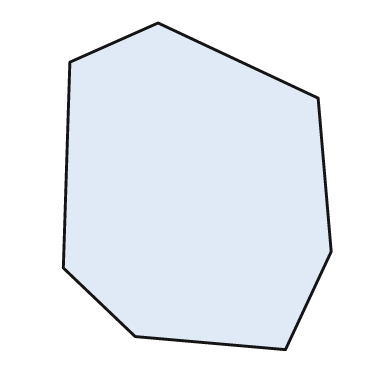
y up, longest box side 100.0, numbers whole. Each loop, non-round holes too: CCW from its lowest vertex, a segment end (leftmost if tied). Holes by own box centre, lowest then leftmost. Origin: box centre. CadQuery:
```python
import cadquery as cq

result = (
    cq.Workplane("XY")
    .moveTo(27.0, -50.0)
    .lineTo(41.0, -20.0)
    .lineTo(37.0, 27.0)
    .lineTo(-12.0, 50.0)
    .lineTo(-39.0, 38.0)
    .lineTo(-41.0, -25.0)
    .lineTo(-19.0, -46.0)
    .close()
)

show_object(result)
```